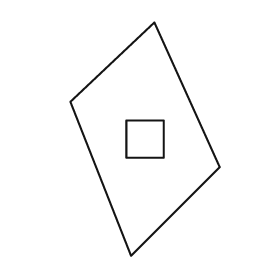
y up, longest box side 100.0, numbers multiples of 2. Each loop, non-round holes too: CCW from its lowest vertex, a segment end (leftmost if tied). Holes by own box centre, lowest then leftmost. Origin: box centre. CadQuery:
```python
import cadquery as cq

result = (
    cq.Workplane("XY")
    .moveTo(-6.0, -50.0)
    .lineTo(32.0, -12.0)
    .lineTo(4.0, 50.0)
    .lineTo(-32.0, 16.0)
    .close()
    .moveTo(-8.0, -8.0)
    .lineTo(8.0, -8.0)
    .lineTo(8.0, 8.0)
    .lineTo(-8.0, 8.0)
    .close()
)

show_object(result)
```